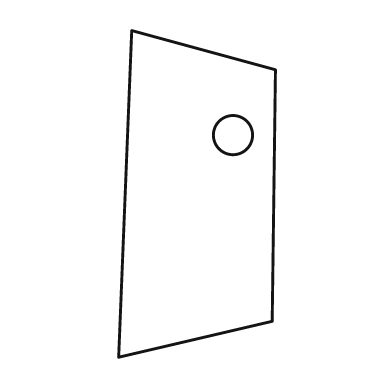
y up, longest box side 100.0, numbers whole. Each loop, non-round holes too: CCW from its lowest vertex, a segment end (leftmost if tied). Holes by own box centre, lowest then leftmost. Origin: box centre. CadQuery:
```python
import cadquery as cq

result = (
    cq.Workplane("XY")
    .moveTo(-24.0, -50.0)
    .lineTo(23.0, -39.0)
    .lineTo(24.0, 38.0)
    .lineTo(-20.0, 50.0)
    .close()
    .moveTo(11.0, 18.0)
    .circle(6.0)
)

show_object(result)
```